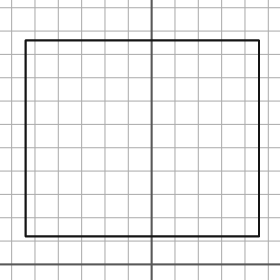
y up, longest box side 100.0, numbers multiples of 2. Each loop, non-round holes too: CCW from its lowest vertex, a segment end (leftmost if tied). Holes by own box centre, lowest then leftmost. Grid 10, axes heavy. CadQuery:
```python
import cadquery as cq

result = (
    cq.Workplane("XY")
    .moveTo(-54.0, 12.0)
    .lineTo(46.0, 12.0)
    .lineTo(46.0, 96.0)
    .lineTo(-54.0, 96.0)
    .close()
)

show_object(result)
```